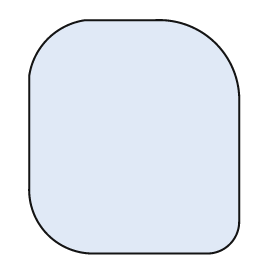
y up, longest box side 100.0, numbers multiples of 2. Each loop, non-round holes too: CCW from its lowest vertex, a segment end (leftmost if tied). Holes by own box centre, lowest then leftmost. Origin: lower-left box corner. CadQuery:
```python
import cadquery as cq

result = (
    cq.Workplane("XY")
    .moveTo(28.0, 0.0)
    .lineTo(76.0, 0.0)
    .threePointArc((86.0, 4.0), (90.0, 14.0))
    .lineTo(90.0, 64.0)
    .threePointArc((80.0, 90.0), (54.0, 100.0))
    .lineTo(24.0, 100.0)
    .threePointArc((8.0, 92.0), (0.0, 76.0))
    .lineTo(0.0, 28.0)
    .threePointArc((8.0, 8.0), (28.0, 0.0))
    .close()
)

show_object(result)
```